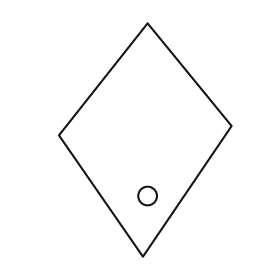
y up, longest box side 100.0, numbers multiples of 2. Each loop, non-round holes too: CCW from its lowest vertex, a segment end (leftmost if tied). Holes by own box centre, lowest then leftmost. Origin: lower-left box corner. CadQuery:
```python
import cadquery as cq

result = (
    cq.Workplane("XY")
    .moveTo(36.0, 0.0)
    .lineTo(74.0, 56.0)
    .lineTo(38.0, 100.0)
    .lineTo(0.0, 52.0)
    .close()
    .moveTo(38.0, 26.0)
    .circle(4.0)
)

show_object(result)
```